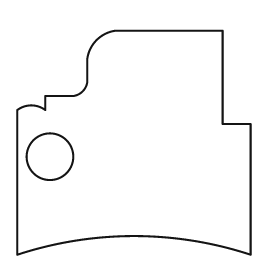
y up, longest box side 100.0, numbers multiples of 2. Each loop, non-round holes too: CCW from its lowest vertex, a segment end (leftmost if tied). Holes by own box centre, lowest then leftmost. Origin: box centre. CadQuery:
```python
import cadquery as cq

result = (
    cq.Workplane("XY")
    .moveTo(-50.0, -48.0)
    .threePointArc((0.0, -40.0), (50.0, -48.0))
    .lineTo(50.0, 8.0)
    .lineTo(38.0, 8.0)
    .lineTo(38.0, 48.0)
    .lineTo(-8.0, 48.0)
    .threePointArc((-16.0, 44.0), (-20.0, 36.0))
    .lineTo(-20.0, 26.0)
    .threePointArc((-22.0, 22.0), (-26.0, 20.0))
    .lineTo(-38.0, 20.0)
    .lineTo(-38.0, 14.0)
    .threePointArc((-44.0, 16.0), (-50.0, 14.0))
    .close()
    .moveTo(-36.0, -6.0)
    .circle(10.0)
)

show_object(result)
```